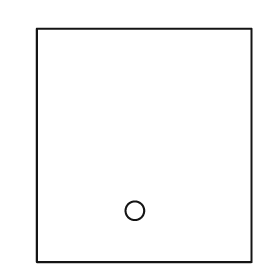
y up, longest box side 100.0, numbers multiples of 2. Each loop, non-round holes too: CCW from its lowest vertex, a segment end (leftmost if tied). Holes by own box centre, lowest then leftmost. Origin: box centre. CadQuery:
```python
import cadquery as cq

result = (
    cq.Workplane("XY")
    .moveTo(-46.0, -50.0)
    .lineTo(46.0, -50.0)
    .lineTo(46.0, 50.0)
    .lineTo(-46.0, 50.0)
    .close()
    .moveTo(-4.0, -28.0)
    .circle(4.0)
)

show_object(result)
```